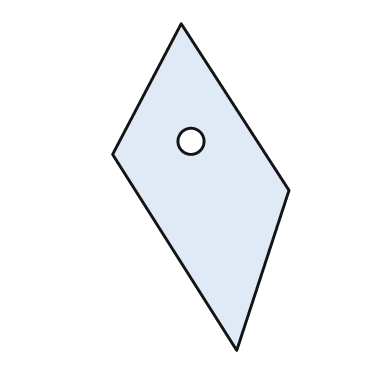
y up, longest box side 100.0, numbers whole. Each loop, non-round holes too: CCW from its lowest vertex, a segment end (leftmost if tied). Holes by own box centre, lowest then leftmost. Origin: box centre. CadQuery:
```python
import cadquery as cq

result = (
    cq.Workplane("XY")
    .moveTo(11.0, -50.0)
    .lineTo(27.0, -1.0)
    .lineTo(-6.0, 50.0)
    .lineTo(-27.0, 10.0)
    .close()
    .moveTo(-3.0, 14.0)
    .circle(4.0)
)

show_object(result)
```